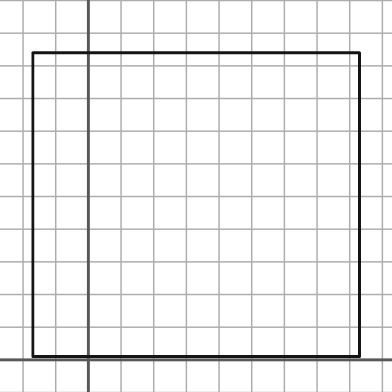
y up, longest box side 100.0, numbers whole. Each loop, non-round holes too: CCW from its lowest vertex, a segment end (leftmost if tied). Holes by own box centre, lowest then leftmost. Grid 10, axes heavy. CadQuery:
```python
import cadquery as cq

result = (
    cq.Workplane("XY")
    .moveTo(-17.0, 1.0)
    .lineTo(83.0, 1.0)
    .lineTo(83.0, 94.0)
    .lineTo(-17.0, 94.0)
    .close()
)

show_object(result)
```